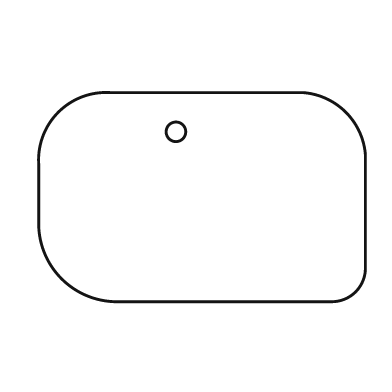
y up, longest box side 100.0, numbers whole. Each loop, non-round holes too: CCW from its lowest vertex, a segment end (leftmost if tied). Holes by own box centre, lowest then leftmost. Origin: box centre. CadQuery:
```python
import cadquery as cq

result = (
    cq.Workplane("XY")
    .moveTo(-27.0, -32.0)
    .lineTo(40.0, -32.0)
    .threePointArc((47.0, -29.0), (50.0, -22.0))
    .lineTo(50.0, 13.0)
    .threePointArc((44.0, 26.0), (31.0, 32.0))
    .lineTo(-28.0, 32.0)
    .threePointArc((-44.0, 26.0), (-50.0, 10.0))
    .lineTo(-50.0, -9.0)
    .threePointArc((-43.0, -25.0), (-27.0, -32.0))
    .close()
    .moveTo(-8.0, 20.0)
    .circle(3.0)
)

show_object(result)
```